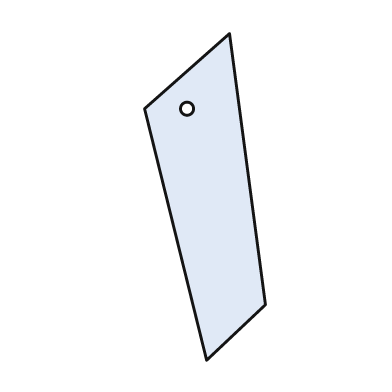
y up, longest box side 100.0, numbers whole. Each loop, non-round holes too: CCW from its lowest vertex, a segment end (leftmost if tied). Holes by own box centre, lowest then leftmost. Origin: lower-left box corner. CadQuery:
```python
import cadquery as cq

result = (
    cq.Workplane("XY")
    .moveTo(19.0, 0.0)
    .lineTo(37.0, 17.0)
    .lineTo(26.0, 100.0)
    .lineTo(0.0, 77.0)
    .close()
    .moveTo(13.0, 77.0)
    .circle(2.0)
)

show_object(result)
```